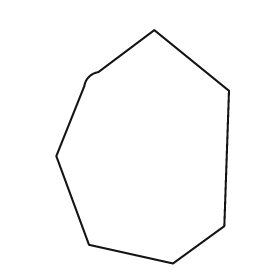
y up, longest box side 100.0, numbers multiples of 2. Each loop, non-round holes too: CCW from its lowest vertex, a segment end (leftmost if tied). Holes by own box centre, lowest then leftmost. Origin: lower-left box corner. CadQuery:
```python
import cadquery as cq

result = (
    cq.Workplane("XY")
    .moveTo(50.0, 0.0)
    .lineTo(72.0, 16.0)
    .lineTo(74.0, 74.0)
    .lineTo(42.0, 100.0)
    .lineTo(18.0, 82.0)
    .threePointArc((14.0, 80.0), (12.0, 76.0))
    .lineTo(0.0, 46.0)
    .lineTo(14.0, 8.0)
    .close()
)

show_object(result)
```